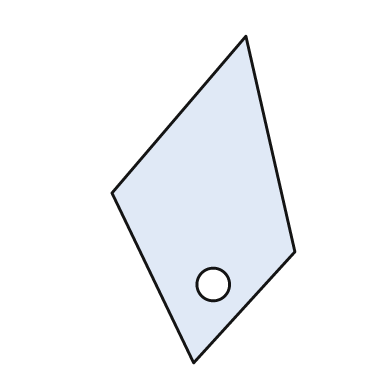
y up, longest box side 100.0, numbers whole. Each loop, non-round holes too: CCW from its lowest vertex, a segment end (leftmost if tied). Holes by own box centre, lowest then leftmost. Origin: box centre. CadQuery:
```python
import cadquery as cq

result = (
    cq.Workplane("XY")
    .moveTo(-3.0, -50.0)
    .lineTo(28.0, -16.0)
    .lineTo(13.0, 50.0)
    .lineTo(-28.0, 2.0)
    .close()
    .moveTo(3.0, -26.0)
    .circle(5.0)
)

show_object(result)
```